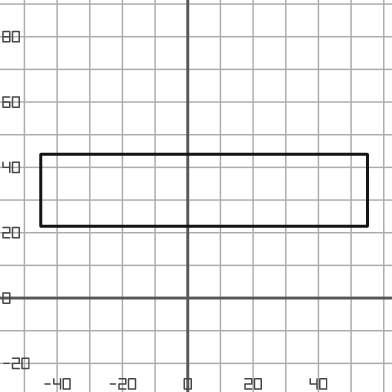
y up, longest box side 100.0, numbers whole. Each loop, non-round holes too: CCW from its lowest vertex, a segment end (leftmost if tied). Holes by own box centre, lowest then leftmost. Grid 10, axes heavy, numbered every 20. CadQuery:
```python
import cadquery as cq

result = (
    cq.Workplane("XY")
    .moveTo(-45.0, 22.0)
    .lineTo(55.0, 22.0)
    .lineTo(55.0, 44.0)
    .lineTo(-45.0, 44.0)
    .close()
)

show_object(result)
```